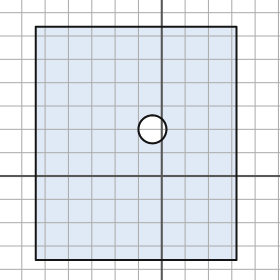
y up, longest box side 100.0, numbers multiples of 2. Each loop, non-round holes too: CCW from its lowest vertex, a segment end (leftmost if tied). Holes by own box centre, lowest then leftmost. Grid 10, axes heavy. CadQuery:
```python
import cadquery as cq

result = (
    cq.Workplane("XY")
    .moveTo(-54.0, -36.0)
    .lineTo(32.0, -36.0)
    .lineTo(32.0, 64.0)
    .lineTo(-54.0, 64.0)
    .close()
    .moveTo(-4.0, 20.0)
    .circle(6.0)
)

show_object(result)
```